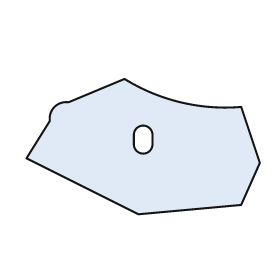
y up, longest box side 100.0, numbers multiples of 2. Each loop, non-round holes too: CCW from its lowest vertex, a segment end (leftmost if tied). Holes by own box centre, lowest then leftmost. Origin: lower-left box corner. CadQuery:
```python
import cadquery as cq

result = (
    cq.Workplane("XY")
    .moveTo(48.0, 0.0)
    .lineTo(92.0, 4.0)
    .lineTo(100.0, 22.0)
    .lineTo(92.0, 46.0)
    .threePointArc((66.0, 48.0), (42.0, 58.0))
    .lineTo(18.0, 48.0)
    .threePointArc((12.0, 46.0), (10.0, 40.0))
    .lineTo(0.0, 24.0)
    .close()
    .moveTo(46.0, 30.0)
    .threePointArc((50.0, 26.0), (54.0, 30.0))
    .lineTo(54.0, 34.0)
    .threePointArc((50.0, 38.0), (46.0, 34.0))
    .close()
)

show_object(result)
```